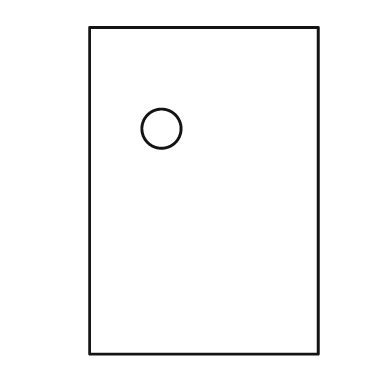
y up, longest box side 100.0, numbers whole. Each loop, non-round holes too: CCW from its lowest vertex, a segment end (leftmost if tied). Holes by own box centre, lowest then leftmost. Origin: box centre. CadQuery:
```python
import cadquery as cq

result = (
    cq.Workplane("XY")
    .moveTo(-35.0, -50.0)
    .lineTo(35.0, -50.0)
    .lineTo(35.0, 50.0)
    .lineTo(-35.0, 50.0)
    .close()
    .moveTo(-13.0, 19.0)
    .circle(6.0)
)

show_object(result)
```